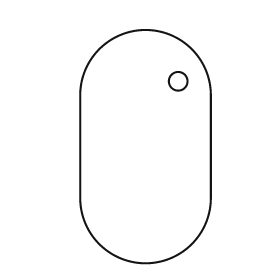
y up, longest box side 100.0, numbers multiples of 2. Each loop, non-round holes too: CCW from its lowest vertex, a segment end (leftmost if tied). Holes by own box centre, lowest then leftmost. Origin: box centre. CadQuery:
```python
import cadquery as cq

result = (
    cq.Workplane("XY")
    .moveTo(-28.0, -22.0)
    .threePointArc((0.0, -50.0), (28.0, -22.0))
    .lineTo(28.0, 22.0)
    .threePointArc((0.0, 50.0), (-28.0, 22.0))
    .close()
    .moveTo(14.0, 28.0)
    .circle(4.0)
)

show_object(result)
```